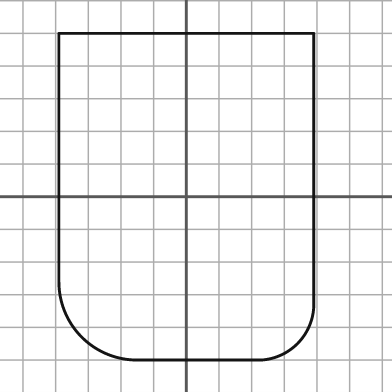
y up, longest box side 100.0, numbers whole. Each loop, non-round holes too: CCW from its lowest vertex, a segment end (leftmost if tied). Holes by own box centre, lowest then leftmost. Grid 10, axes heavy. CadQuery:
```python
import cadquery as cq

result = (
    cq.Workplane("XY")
    .moveTo(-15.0, -50.0)
    .lineTo(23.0, -50.0)
    .threePointArc((34.0, -45.0), (39.0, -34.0))
    .lineTo(39.0, 50.0)
    .lineTo(-39.0, 50.0)
    .lineTo(-39.0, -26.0)
    .threePointArc((-32.0, -43.0), (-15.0, -50.0))
    .close()
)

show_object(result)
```